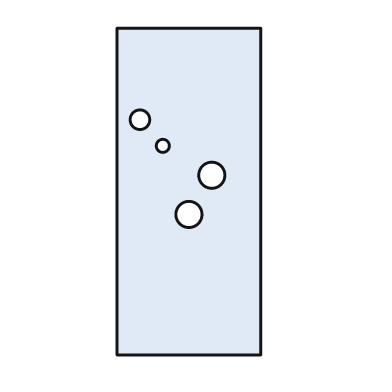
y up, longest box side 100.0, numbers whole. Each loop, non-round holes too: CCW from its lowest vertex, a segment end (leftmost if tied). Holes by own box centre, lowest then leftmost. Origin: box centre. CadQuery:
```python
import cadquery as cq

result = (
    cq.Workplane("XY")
    .moveTo(-22.0, -50.0)
    .lineTo(22.0, -50.0)
    .lineTo(22.0, 50.0)
    .lineTo(-22.0, 50.0)
    .close()
    .moveTo(0.0, -7.0)
    .circle(4.0)
    .moveTo(7.0, 5.0)
    .circle(4.0)
    .moveTo(-8.0, 14.0)
    .circle(2.0)
    .moveTo(-15.0, 22.0)
    .circle(3.0)
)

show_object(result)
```